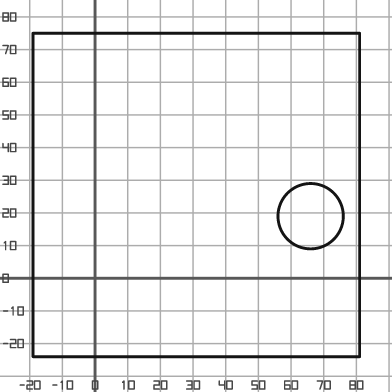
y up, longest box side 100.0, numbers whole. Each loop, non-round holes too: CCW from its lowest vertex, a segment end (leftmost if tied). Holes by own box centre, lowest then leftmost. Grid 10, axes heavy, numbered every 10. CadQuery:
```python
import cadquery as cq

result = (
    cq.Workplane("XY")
    .moveTo(-19.0, -24.0)
    .lineTo(81.0, -24.0)
    .lineTo(81.0, 75.0)
    .lineTo(-19.0, 75.0)
    .close()
    .moveTo(66.0, 19.0)
    .circle(10.0)
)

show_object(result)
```